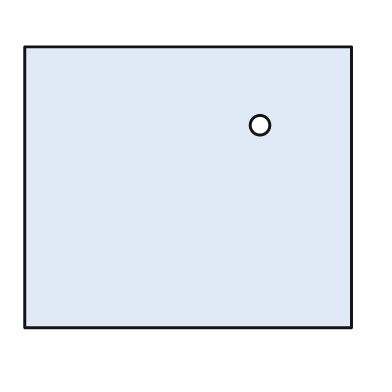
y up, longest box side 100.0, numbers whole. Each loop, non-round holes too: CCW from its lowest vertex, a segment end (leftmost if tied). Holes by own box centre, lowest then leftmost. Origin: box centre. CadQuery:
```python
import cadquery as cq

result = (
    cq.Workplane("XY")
    .moveTo(-50.0, -43.0)
    .lineTo(50.0, -43.0)
    .lineTo(50.0, 43.0)
    .lineTo(-50.0, 43.0)
    .close()
    .moveTo(22.0, 19.0)
    .circle(3.0)
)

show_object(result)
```